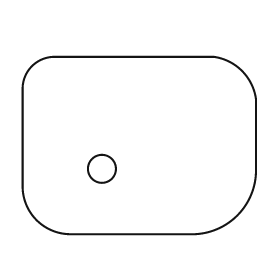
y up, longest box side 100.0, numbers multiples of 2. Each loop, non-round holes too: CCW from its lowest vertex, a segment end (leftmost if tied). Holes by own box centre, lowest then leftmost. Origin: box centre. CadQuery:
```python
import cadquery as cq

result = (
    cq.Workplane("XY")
    .moveTo(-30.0, -38.0)
    .lineTo(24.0, -38.0)
    .threePointArc((42.0, -30.0), (50.0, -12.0))
    .lineTo(50.0, 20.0)
    .threePointArc((44.0, 32.0), (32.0, 38.0))
    .lineTo(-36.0, 38.0)
    .threePointArc((-46.0, 34.0), (-50.0, 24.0))
    .lineTo(-50.0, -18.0)
    .threePointArc((-44.0, -32.0), (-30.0, -38.0))
    .close()
    .moveTo(-16.0, -10.0)
    .circle(6.0)
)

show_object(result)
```